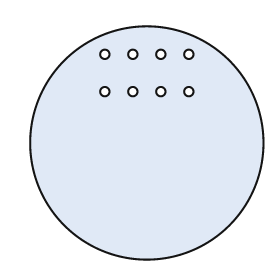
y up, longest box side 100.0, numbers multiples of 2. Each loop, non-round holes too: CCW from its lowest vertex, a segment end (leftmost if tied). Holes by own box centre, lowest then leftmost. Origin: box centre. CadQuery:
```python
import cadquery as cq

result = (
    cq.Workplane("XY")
    .moveTo(0.0, 0.0)
    .circle(50.0)
    .moveTo(-18.0, 22.0)
    .circle(2.0)
    .moveTo(-6.0, 22.0)
    .circle(2.0)
    .moveTo(6.0, 22.0)
    .circle(2.0)
    .moveTo(18.0, 22.0)
    .circle(2.0)
    .moveTo(-18.0, 38.0)
    .circle(2.0)
    .moveTo(-6.0, 38.0)
    .circle(2.0)
    .moveTo(6.0, 38.0)
    .circle(2.0)
    .moveTo(18.0, 38.0)
    .circle(2.0)
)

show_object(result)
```